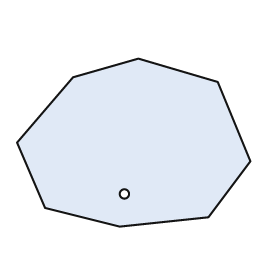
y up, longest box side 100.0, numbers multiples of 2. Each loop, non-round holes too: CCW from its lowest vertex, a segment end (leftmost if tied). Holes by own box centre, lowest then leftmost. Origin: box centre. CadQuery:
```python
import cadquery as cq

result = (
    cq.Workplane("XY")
    .moveTo(-6.0, -36.0)
    .lineTo(32.0, -32.0)
    .lineTo(50.0, -8.0)
    .lineTo(36.0, 26.0)
    .lineTo(2.0, 36.0)
    .lineTo(-26.0, 28.0)
    .lineTo(-50.0, 0.0)
    .lineTo(-38.0, -28.0)
    .close()
    .moveTo(-4.0, -22.0)
    .circle(2.0)
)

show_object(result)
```